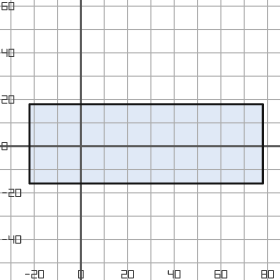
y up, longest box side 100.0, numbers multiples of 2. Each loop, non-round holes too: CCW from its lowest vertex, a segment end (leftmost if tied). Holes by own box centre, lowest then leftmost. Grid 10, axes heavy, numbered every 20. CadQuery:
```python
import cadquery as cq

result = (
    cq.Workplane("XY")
    .moveTo(-22.0, -16.0)
    .lineTo(78.0, -16.0)
    .lineTo(78.0, 18.0)
    .lineTo(-22.0, 18.0)
    .close()
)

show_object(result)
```